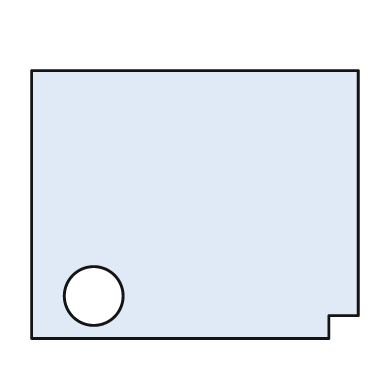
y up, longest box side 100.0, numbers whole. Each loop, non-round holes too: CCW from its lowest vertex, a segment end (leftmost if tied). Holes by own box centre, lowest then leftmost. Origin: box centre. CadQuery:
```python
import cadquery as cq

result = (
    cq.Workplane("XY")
    .moveTo(-50.0, -41.0)
    .lineTo(41.0, -41.0)
    .lineTo(41.0, -34.0)
    .lineTo(50.0, -34.0)
    .lineTo(50.0, 41.0)
    .lineTo(-50.0, 41.0)
    .close()
    .moveTo(-31.0, -28.0)
    .circle(9.0)
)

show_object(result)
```